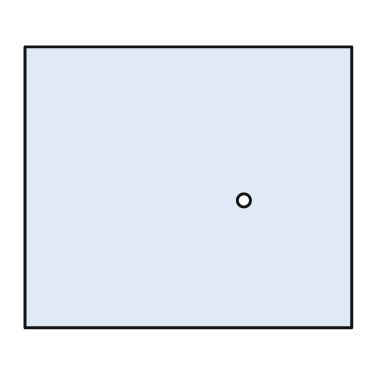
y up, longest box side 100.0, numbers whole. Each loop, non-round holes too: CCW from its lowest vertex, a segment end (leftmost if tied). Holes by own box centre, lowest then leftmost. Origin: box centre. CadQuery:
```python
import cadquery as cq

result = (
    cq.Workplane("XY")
    .moveTo(-50.0, -43.0)
    .lineTo(50.0, -43.0)
    .lineTo(50.0, 43.0)
    .lineTo(-50.0, 43.0)
    .close()
    .moveTo(17.0, -4.0)
    .circle(2.0)
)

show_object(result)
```